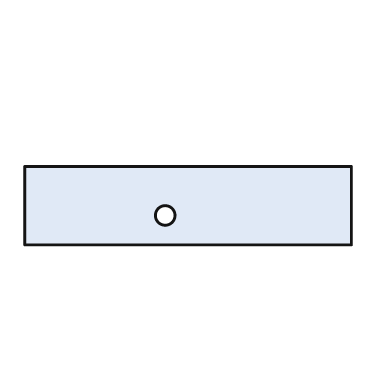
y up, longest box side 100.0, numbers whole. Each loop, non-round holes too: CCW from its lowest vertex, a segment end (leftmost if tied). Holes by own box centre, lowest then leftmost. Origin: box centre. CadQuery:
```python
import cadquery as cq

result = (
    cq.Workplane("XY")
    .moveTo(-50.0, -12.0)
    .lineTo(50.0, -12.0)
    .lineTo(50.0, 12.0)
    .lineTo(-50.0, 12.0)
    .close()
    .moveTo(-7.0, -3.0)
    .circle(3.0)
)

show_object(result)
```